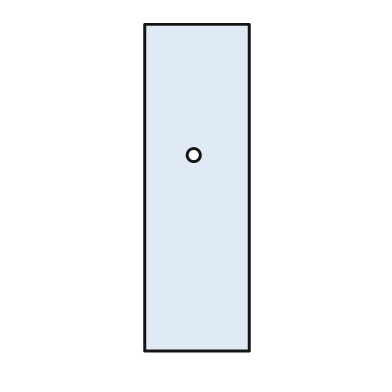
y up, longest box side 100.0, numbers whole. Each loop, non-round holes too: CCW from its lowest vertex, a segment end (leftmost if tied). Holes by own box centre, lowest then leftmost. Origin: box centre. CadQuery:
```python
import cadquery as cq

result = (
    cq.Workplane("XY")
    .moveTo(-16.0, -50.0)
    .lineTo(16.0, -50.0)
    .lineTo(16.0, 50.0)
    .lineTo(-16.0, 50.0)
    .close()
    .moveTo(-1.0, 10.0)
    .circle(2.0)
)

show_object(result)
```